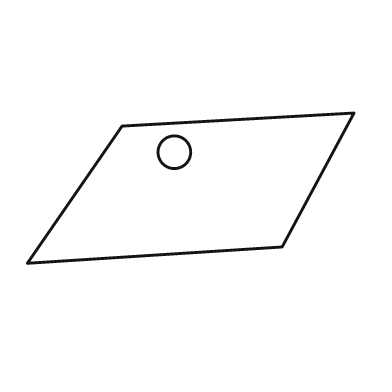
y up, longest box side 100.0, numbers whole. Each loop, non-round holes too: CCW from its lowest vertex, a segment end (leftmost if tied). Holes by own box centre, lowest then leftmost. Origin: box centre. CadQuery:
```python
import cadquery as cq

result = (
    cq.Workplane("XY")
    .moveTo(-50.0, -23.0)
    .lineTo(28.0, -18.0)
    .lineTo(50.0, 23.0)
    .lineTo(-21.0, 19.0)
    .close()
    .moveTo(-5.0, 11.0)
    .circle(5.0)
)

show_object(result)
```